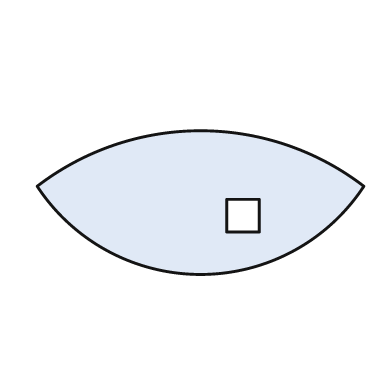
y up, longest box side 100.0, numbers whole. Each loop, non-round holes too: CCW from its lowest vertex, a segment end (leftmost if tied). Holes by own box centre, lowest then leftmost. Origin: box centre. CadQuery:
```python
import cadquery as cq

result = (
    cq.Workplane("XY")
    .moveTo(-50.0, 5.0)
    .threePointArc((0.0, -22.0), (50.0, 5.0))
    .threePointArc((0.0, 22.0), (-50.0, 5.0))
    .close()
    .moveTo(8.0, -9.0)
    .lineTo(18.0, -9.0)
    .lineTo(18.0, 1.0)
    .lineTo(8.0, 1.0)
    .close()
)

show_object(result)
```